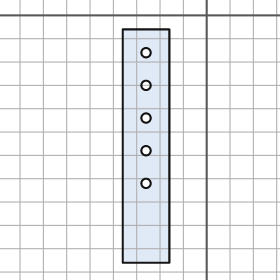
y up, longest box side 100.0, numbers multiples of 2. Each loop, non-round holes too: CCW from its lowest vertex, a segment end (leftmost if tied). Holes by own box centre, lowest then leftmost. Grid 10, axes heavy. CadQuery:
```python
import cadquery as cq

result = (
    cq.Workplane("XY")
    .moveTo(-36.0, -106.0)
    .lineTo(-16.0, -106.0)
    .lineTo(-16.0, -6.0)
    .lineTo(-36.0, -6.0)
    .close()
    .moveTo(-26.0, -72.0)
    .circle(2.0)
    .moveTo(-26.0, -58.0)
    .circle(2.0)
    .moveTo(-26.0, -44.0)
    .circle(2.0)
    .moveTo(-26.0, -30.0)
    .circle(2.0)
    .moveTo(-26.0, -16.0)
    .circle(2.0)
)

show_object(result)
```